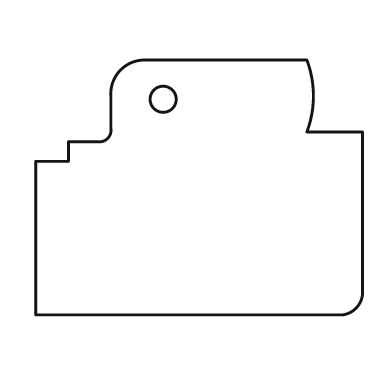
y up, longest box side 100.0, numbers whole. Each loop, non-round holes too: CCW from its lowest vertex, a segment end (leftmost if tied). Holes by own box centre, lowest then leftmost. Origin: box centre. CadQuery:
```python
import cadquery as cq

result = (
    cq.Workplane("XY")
    .moveTo(-50.0, -39.0)
    .lineTo(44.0, -39.0)
    .threePointArc((48.0, -37.0), (50.0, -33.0))
    .lineTo(50.0, 17.0)
    .lineTo(33.0, 17.0)
    .threePointArc((35.0, 28.0), (33.0, 39.0))
    .lineTo(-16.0, 39.0)
    .threePointArc((-24.0, 36.0), (-27.0, 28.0))
    .lineTo(-27.0, 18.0)
    .threePointArc((-28.0, 15.0), (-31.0, 14.0))
    .lineTo(-40.0, 14.0)
    .lineTo(-40.0, 8.0)
    .lineTo(-50.0, 8.0)
    .close()
    .moveTo(-11.0, 27.0)
    .circle(4.0)
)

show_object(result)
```